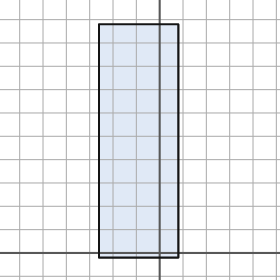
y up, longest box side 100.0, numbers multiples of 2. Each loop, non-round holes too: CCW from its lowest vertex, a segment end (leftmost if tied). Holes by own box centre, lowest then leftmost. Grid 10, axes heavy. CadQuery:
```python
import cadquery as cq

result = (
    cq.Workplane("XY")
    .moveTo(-26.0, -2.0)
    .lineTo(8.0, -2.0)
    .lineTo(8.0, 98.0)
    .lineTo(-26.0, 98.0)
    .close()
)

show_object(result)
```